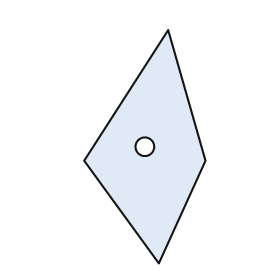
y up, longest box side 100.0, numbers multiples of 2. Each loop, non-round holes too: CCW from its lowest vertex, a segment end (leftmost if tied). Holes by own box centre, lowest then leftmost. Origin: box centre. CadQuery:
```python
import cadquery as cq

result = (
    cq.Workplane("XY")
    .moveTo(6.0, -50.0)
    .lineTo(26.0, -6.0)
    .lineTo(10.0, 50.0)
    .lineTo(-26.0, -6.0)
    .close()
    .moveTo(0.0, 0.0)
    .circle(4.0)
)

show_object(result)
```